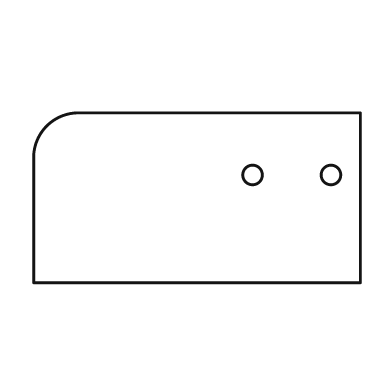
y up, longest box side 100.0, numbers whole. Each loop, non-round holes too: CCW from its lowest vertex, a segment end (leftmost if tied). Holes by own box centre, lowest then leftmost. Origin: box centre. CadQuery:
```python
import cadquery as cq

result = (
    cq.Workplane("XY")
    .moveTo(-50.0, -26.0)
    .lineTo(50.0, -26.0)
    .lineTo(50.0, 26.0)
    .lineTo(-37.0, 26.0)
    .threePointArc((-46.0, 22.0), (-50.0, 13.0))
    .close()
    .moveTo(17.0, 7.0)
    .circle(3.0)
    .moveTo(41.0, 7.0)
    .circle(3.0)
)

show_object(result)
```